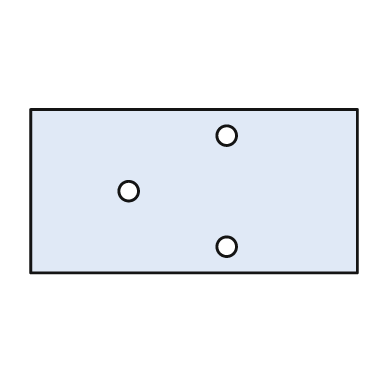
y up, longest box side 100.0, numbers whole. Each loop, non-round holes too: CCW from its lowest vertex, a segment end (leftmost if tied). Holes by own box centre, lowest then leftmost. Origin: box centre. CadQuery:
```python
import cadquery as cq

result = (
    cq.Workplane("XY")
    .moveTo(-50.0, -25.0)
    .lineTo(50.0, -25.0)
    .lineTo(50.0, 25.0)
    .lineTo(-50.0, 25.0)
    .close()
    .moveTo(10.0, -17.0)
    .circle(3.0)
    .moveTo(-20.0, 0.0)
    .circle(3.0)
    .moveTo(10.0, 17.0)
    .circle(3.0)
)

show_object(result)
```